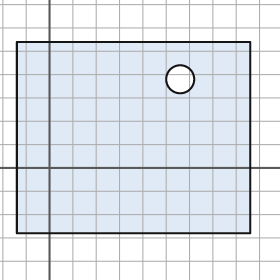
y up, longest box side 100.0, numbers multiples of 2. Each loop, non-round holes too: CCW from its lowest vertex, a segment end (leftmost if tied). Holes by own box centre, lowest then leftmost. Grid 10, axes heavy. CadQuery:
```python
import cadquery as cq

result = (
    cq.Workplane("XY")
    .moveTo(-14.0, -28.0)
    .lineTo(86.0, -28.0)
    .lineTo(86.0, 54.0)
    .lineTo(-14.0, 54.0)
    .close()
    .moveTo(56.0, 38.0)
    .circle(6.0)
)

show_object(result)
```